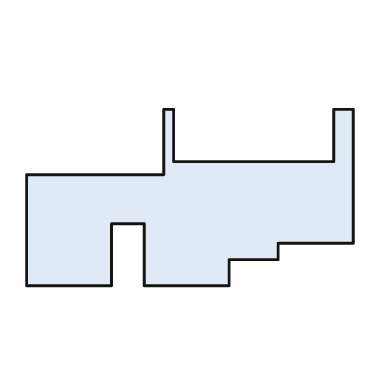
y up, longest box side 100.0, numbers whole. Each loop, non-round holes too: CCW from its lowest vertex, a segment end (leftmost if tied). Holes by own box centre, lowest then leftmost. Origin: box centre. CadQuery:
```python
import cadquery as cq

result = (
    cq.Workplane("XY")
    .moveTo(-50.0, -27.0)
    .lineTo(-24.0, -27.0)
    .lineTo(-24.0, -8.0)
    .lineTo(-14.0, -8.0)
    .lineTo(-14.0, -27.0)
    .lineTo(12.0, -27.0)
    .lineTo(12.0, -19.0)
    .lineTo(27.0, -19.0)
    .lineTo(27.0, -14.0)
    .lineTo(50.0, -14.0)
    .lineTo(50.0, 27.0)
    .lineTo(44.0, 27.0)
    .lineTo(44.0, 11.0)
    .lineTo(-5.0, 11.0)
    .lineTo(-5.0, 27.0)
    .lineTo(-8.0, 27.0)
    .lineTo(-8.0, 7.0)
    .lineTo(-50.0, 7.0)
    .close()
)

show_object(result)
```